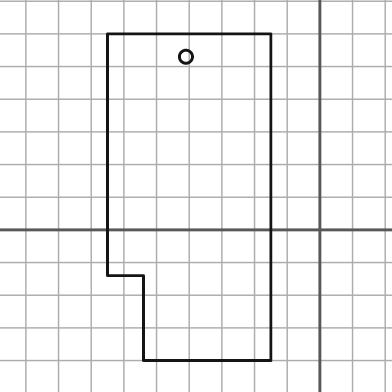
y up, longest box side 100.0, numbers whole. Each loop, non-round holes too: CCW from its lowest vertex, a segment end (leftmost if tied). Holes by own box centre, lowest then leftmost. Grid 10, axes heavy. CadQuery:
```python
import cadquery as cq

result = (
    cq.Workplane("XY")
    .moveTo(-54.0, -40.0)
    .lineTo(-15.0, -40.0)
    .lineTo(-15.0, 60.0)
    .lineTo(-65.0, 60.0)
    .lineTo(-65.0, -14.0)
    .lineTo(-54.0, -14.0)
    .close()
    .moveTo(-41.0, 53.0)
    .circle(2.0)
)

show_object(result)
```